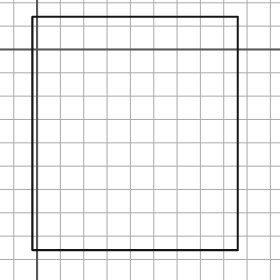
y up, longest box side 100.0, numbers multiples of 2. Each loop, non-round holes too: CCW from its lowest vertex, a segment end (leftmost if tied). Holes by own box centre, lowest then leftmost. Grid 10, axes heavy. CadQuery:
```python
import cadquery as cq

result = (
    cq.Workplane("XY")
    .moveTo(-2.0, -86.0)
    .lineTo(86.0, -86.0)
    .lineTo(86.0, 14.0)
    .lineTo(-2.0, 14.0)
    .close()
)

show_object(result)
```